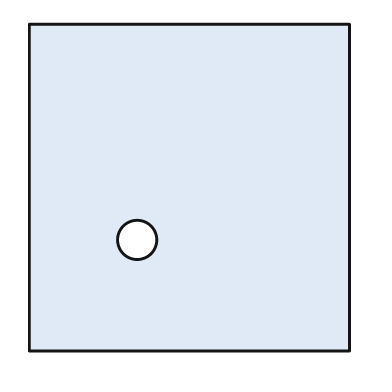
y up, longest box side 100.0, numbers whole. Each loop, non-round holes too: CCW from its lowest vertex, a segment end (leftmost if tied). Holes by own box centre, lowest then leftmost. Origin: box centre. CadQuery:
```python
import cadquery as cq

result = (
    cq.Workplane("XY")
    .moveTo(-49.0, -50.0)
    .lineTo(49.0, -50.0)
    .lineTo(49.0, 50.0)
    .lineTo(-49.0, 50.0)
    .close()
    .moveTo(-16.0, -16.0)
    .circle(6.0)
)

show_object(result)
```